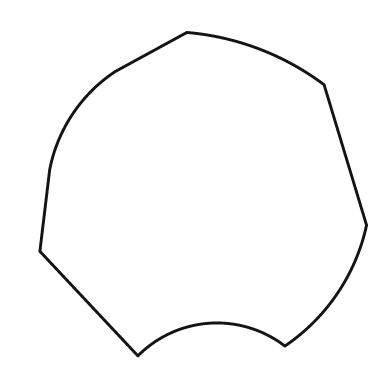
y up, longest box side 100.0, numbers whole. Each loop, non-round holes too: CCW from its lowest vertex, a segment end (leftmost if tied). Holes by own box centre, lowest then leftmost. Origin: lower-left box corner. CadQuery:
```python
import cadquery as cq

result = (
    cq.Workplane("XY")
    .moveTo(30.0, 0.0)
    .threePointArc((52.0, 10.0), (75.0, 3.0))
    .threePointArc((91.0, 19.0), (100.0, 40.0))
    .lineTo(87.0, 83.0)
    .threePointArc((67.0, 94.0), (45.0, 99.0))
    .lineTo(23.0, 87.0)
    .threePointArc((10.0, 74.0), (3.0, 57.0))
    .lineTo(0.0, 32.0)
    .close()
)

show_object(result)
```